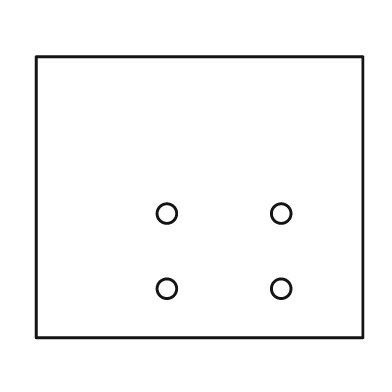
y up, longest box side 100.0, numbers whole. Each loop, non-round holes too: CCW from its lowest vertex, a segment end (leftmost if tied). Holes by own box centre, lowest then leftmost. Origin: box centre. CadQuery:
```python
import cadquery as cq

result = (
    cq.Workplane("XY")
    .moveTo(-50.0, -43.0)
    .lineTo(50.0, -43.0)
    .lineTo(50.0, 43.0)
    .lineTo(-50.0, 43.0)
    .close()
    .moveTo(-10.0, -28.0)
    .circle(3.0)
    .moveTo(25.0, -28.0)
    .circle(3.0)
    .moveTo(-10.0, -5.0)
    .circle(3.0)
    .moveTo(25.0, -5.0)
    .circle(3.0)
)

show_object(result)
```